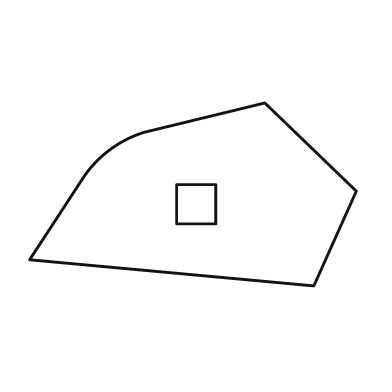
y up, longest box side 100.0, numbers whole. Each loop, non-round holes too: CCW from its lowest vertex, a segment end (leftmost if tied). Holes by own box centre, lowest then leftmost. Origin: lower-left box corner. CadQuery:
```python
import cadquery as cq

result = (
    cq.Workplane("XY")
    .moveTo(87.0, 0.0)
    .lineTo(100.0, 29.0)
    .lineTo(72.0, 56.0)
    .lineTo(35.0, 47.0)
    .threePointArc((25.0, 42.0), (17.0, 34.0))
    .lineTo(0.0, 8.0)
    .close()
    .moveTo(45.0, 19.0)
    .lineTo(57.0, 19.0)
    .lineTo(57.0, 31.0)
    .lineTo(45.0, 31.0)
    .close()
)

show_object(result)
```